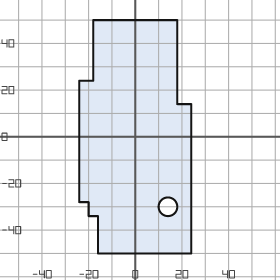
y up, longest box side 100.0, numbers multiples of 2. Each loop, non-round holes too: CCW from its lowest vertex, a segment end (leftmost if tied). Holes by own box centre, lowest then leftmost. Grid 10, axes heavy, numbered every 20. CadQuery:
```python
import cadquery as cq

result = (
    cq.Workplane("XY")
    .moveTo(-16.0, -50.0)
    .lineTo(24.0, -50.0)
    .lineTo(24.0, 14.0)
    .lineTo(18.0, 14.0)
    .lineTo(18.0, 50.0)
    .lineTo(-18.0, 50.0)
    .lineTo(-18.0, 24.0)
    .lineTo(-24.0, 24.0)
    .lineTo(-24.0, -28.0)
    .lineTo(-20.0, -28.0)
    .lineTo(-20.0, -34.0)
    .lineTo(-16.0, -34.0)
    .close()
    .moveTo(14.0, -30.0)
    .circle(4.0)
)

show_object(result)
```